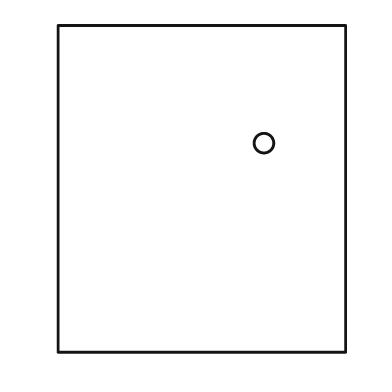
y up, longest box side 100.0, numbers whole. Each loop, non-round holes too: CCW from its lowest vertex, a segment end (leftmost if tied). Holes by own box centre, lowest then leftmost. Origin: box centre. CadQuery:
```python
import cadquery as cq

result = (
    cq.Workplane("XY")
    .moveTo(-44.0, -50.0)
    .lineTo(44.0, -50.0)
    .lineTo(44.0, 50.0)
    .lineTo(-44.0, 50.0)
    .close()
    .moveTo(19.0, 14.0)
    .circle(3.0)
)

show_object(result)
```